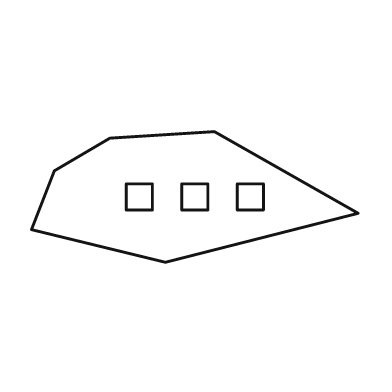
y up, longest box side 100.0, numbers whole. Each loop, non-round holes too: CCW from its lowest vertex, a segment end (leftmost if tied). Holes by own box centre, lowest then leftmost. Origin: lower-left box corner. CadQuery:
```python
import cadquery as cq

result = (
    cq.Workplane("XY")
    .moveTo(41.0, 0.0)
    .lineTo(100.0, 15.0)
    .lineTo(56.0, 40.0)
    .lineTo(24.0, 38.0)
    .lineTo(7.0, 28.0)
    .lineTo(0.0, 10.0)
    .close()
    .moveTo(29.0, 16.0)
    .lineTo(37.0, 16.0)
    .lineTo(37.0, 24.0)
    .lineTo(29.0, 24.0)
    .close()
    .moveTo(46.0, 16.0)
    .lineTo(54.0, 16.0)
    .lineTo(54.0, 24.0)
    .lineTo(46.0, 24.0)
    .close()
    .moveTo(63.0, 16.0)
    .lineTo(71.0, 16.0)
    .lineTo(71.0, 24.0)
    .lineTo(63.0, 24.0)
    .close()
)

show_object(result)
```